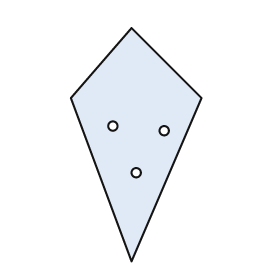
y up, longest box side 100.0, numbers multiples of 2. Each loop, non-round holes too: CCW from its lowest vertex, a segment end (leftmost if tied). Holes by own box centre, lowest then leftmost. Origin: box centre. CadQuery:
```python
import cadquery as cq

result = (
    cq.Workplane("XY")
    .moveTo(-2.0, -50.0)
    .lineTo(28.0, 20.0)
    .lineTo(-2.0, 50.0)
    .lineTo(-28.0, 20.0)
    .close()
    .moveTo(0.0, -12.0)
    .circle(2.0)
    .moveTo(12.0, 6.0)
    .circle(2.0)
    .moveTo(-10.0, 8.0)
    .circle(2.0)
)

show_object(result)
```